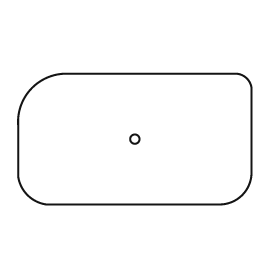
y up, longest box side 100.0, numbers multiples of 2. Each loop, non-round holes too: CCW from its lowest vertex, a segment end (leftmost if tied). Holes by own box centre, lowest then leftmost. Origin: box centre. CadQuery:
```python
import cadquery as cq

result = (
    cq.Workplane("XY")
    .moveTo(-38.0, -28.0)
    .lineTo(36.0, -28.0)
    .threePointArc((46.0, -24.0), (50.0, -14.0))
    .lineTo(50.0, 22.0)
    .threePointArc((48.0, 26.0), (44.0, 28.0))
    .lineTo(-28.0, 28.0)
    .threePointArc((-44.0, 22.0), (-50.0, 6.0))
    .lineTo(-50.0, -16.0)
    .threePointArc((-46.0, -24.0), (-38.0, -28.0))
    .close()
    .moveTo(0.0, 0.0)
    .circle(2.0)
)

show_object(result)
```